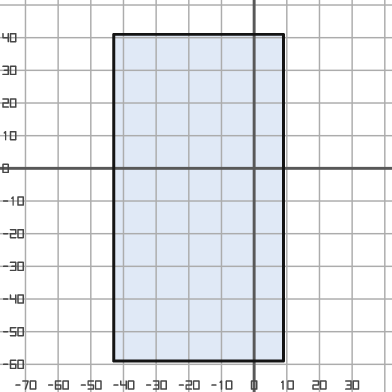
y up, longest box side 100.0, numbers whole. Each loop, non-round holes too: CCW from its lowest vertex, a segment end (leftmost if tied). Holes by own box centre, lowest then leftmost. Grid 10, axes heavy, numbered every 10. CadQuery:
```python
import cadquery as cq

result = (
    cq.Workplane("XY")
    .moveTo(-43.0, -59.0)
    .lineTo(9.0, -59.0)
    .lineTo(9.0, 41.0)
    .lineTo(-43.0, 41.0)
    .close()
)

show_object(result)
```